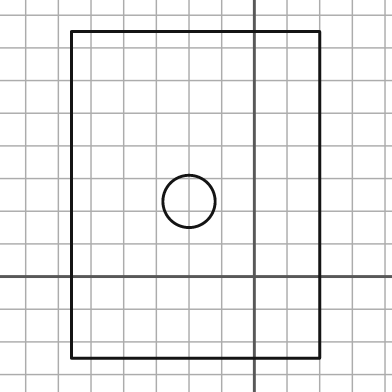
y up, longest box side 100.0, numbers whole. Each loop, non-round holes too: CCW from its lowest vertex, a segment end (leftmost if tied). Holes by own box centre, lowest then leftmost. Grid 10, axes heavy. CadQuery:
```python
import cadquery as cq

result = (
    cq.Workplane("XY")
    .moveTo(-56.0, -25.0)
    .lineTo(20.0, -25.0)
    .lineTo(20.0, 75.0)
    .lineTo(-56.0, 75.0)
    .close()
    .moveTo(-20.0, 23.0)
    .circle(8.0)
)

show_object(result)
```